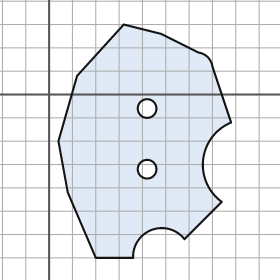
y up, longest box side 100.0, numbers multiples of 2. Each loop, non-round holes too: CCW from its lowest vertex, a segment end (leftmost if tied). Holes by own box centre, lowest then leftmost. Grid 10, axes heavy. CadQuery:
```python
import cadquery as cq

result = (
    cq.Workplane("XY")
    .moveTo(20.0, -70.0)
    .lineTo(36.0, -70.0)
    .threePointArc((44.0, -58.0), (58.0, -62.0))
    .lineTo(74.0, -46.0)
    .threePointArc((66.0, -28.0), (78.0, -12.0))
    .lineTo(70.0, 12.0)
    .threePointArc((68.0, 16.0), (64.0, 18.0))
    .lineTo(48.0, 26.0)
    .lineTo(32.0, 30.0)
    .lineTo(12.0, 8.0)
    .lineTo(4.0, -20.0)
    .lineTo(8.0, -42.0)
    .close()
    .moveTo(42.0, -32.0)
    .circle(4.0)
    .moveTo(42.0, -6.0)
    .circle(4.0)
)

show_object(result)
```